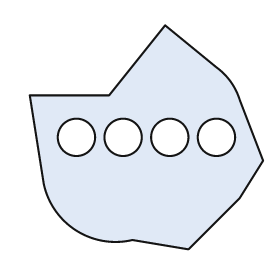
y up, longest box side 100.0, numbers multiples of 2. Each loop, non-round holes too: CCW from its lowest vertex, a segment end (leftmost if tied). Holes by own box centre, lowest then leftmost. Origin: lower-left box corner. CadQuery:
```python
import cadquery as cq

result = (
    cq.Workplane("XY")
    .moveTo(68.0, 0.0)
    .lineTo(90.0, 22.0)
    .lineTo(100.0, 38.0)
    .lineTo(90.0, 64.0)
    .threePointArc((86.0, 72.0), (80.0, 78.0))
    .lineTo(58.0, 96.0)
    .lineTo(34.0, 66.0)
    .lineTo(0.0, 66.0)
    .lineTo(6.0, 28.0)
    .threePointArc((20.0, 8.0), (44.0, 4.0))
    .close()
    .moveTo(20.0, 48.0)
    .circle(8.0)
    .moveTo(40.0, 48.0)
    .circle(8.0)
    .moveTo(60.0, 48.0)
    .circle(8.0)
    .moveTo(80.0, 48.0)
    .circle(8.0)
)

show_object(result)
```